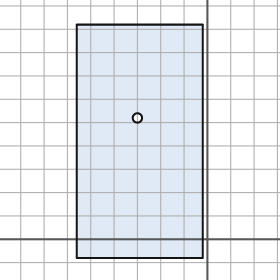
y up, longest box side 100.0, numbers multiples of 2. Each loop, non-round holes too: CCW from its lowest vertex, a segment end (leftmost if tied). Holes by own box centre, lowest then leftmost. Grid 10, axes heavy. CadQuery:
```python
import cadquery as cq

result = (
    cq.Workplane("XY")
    .moveTo(-56.0, -8.0)
    .lineTo(-2.0, -8.0)
    .lineTo(-2.0, 92.0)
    .lineTo(-56.0, 92.0)
    .close()
    .moveTo(-30.0, 52.0)
    .circle(2.0)
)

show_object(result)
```